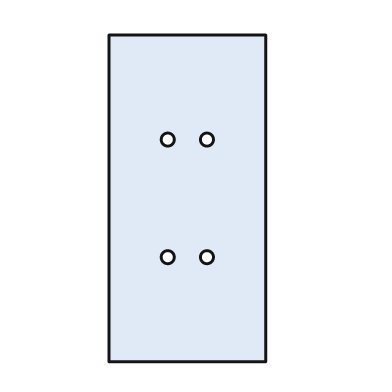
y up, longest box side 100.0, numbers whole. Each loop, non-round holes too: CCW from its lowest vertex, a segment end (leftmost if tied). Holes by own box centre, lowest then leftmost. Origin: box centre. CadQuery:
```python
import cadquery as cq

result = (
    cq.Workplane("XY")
    .moveTo(-24.0, -50.0)
    .lineTo(24.0, -50.0)
    .lineTo(24.0, 50.0)
    .lineTo(-24.0, 50.0)
    .close()
    .moveTo(-6.0, -18.0)
    .circle(2.0)
    .moveTo(6.0, -18.0)
    .circle(2.0)
    .moveTo(-6.0, 18.0)
    .circle(2.0)
    .moveTo(6.0, 18.0)
    .circle(2.0)
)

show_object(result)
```